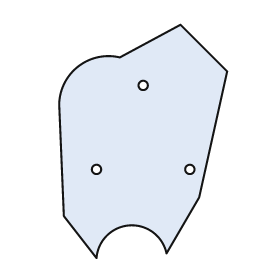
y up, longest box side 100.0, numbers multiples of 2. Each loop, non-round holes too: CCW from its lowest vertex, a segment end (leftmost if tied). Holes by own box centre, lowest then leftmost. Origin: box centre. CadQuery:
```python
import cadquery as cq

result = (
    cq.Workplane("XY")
    .moveTo(-20.0, -50.0)
    .threePointArc((-6.0, -36.0), (10.0, -48.0))
    .lineTo(24.0, -24.0)
    .lineTo(36.0, 30.0)
    .lineTo(16.0, 50.0)
    .lineTo(-10.0, 36.0)
    .threePointArc((-28.0, 32.0), (-36.0, 16.0))
    .lineTo(-34.0, -32.0)
    .close()
    .moveTo(-20.0, -12.0)
    .circle(2.0)
    .moveTo(20.0, -12.0)
    .circle(2.0)
    .moveTo(0.0, 24.0)
    .circle(2.0)
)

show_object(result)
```